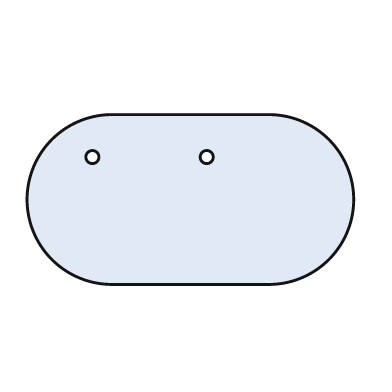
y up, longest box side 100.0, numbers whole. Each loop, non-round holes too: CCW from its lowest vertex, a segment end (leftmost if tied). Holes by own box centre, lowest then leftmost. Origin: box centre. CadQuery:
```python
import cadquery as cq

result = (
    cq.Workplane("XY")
    .moveTo(-24.0, -26.0)
    .lineTo(24.0, -26.0)
    .threePointArc((50.0, 0.0), (24.0, 26.0))
    .lineTo(-24.0, 26.0)
    .threePointArc((-50.0, 0.0), (-24.0, -26.0))
    .close()
    .moveTo(-30.0, 13.0)
    .circle(2.0)
    .moveTo(5.0, 13.0)
    .circle(2.0)
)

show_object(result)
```